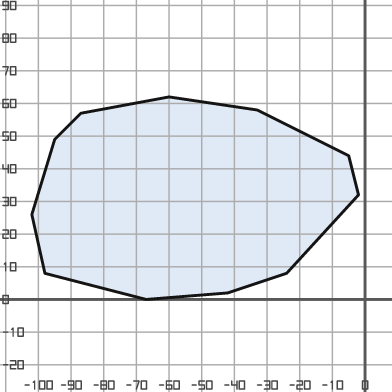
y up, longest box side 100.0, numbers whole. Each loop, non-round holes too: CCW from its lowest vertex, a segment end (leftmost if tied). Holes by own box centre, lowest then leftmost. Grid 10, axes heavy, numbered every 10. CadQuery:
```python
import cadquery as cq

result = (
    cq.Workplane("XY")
    .moveTo(-67.0, 0.0)
    .lineTo(-42.0, 2.0)
    .lineTo(-24.0, 8.0)
    .lineTo(-2.0, 32.0)
    .lineTo(-5.0, 44.0)
    .lineTo(-33.0, 58.0)
    .lineTo(-60.0, 62.0)
    .lineTo(-87.0, 57.0)
    .lineTo(-95.0, 49.0)
    .lineTo(-102.0, 26.0)
    .lineTo(-98.0, 8.0)
    .close()
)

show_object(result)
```